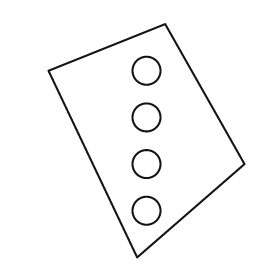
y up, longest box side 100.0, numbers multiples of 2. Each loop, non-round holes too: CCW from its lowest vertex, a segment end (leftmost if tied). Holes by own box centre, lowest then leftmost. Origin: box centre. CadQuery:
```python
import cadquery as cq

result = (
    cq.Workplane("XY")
    .moveTo(-4.0, -50.0)
    .lineTo(42.0, -10.0)
    .lineTo(8.0, 50.0)
    .lineTo(-42.0, 30.0)
    .close()
    .moveTo(0.0, -30.0)
    .circle(6.0)
    .moveTo(0.0, -10.0)
    .circle(6.0)
    .moveTo(0.0, 10.0)
    .circle(6.0)
    .moveTo(0.0, 30.0)
    .circle(6.0)
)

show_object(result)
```